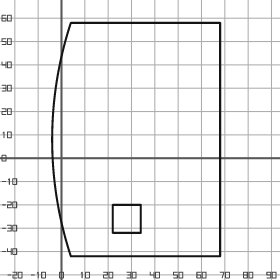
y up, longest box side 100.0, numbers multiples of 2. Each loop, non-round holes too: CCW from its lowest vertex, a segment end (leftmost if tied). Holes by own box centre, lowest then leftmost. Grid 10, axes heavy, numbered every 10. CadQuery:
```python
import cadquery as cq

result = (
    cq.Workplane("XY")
    .moveTo(4.0, -42.0)
    .lineTo(68.0, -42.0)
    .lineTo(68.0, 58.0)
    .lineTo(4.0, 58.0)
    .threePointArc((-4.0, 8.0), (4.0, -42.0))
    .close()
    .moveTo(22.0, -32.0)
    .lineTo(34.0, -32.0)
    .lineTo(34.0, -20.0)
    .lineTo(22.0, -20.0)
    .close()
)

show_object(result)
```